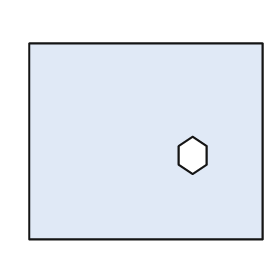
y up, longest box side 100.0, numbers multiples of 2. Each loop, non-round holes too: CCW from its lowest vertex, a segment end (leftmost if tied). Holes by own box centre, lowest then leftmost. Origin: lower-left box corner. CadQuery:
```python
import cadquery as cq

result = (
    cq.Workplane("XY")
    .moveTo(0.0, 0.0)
    .lineTo(100.0, 0.0)
    .lineTo(100.0, 84.0)
    .lineTo(0.0, 84.0)
    .close()
    .moveTo(70.0, 28.0)
    .lineTo(76.0, 32.0)
    .lineTo(76.0, 40.0)
    .lineTo(70.0, 44.0)
    .lineTo(64.0, 40.0)
    .lineTo(64.0, 32.0)
    .close()
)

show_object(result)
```